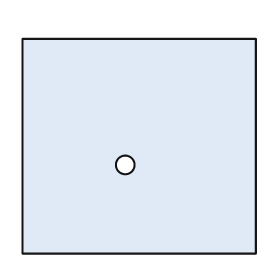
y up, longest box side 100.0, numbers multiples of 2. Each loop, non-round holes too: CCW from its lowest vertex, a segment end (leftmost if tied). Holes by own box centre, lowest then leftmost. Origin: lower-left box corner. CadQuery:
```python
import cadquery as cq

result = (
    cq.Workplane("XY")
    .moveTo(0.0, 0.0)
    .lineTo(100.0, 0.0)
    .lineTo(100.0, 92.0)
    .lineTo(0.0, 92.0)
    .close()
    .moveTo(44.0, 38.0)
    .circle(4.0)
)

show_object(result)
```